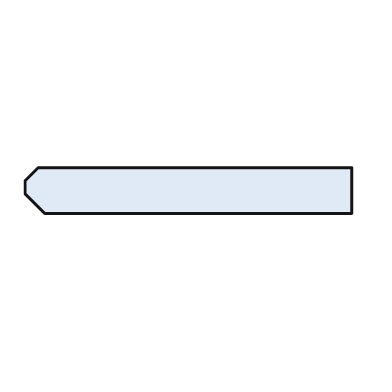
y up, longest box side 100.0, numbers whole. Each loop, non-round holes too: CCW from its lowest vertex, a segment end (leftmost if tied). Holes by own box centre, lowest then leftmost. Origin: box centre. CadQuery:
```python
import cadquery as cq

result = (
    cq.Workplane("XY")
    .moveTo(-44.0, -7.0)
    .lineTo(50.0, -7.0)
    .lineTo(50.0, 7.0)
    .lineTo(-46.0, 7.0)
    .lineTo(-50.0, 3.0)
    .lineTo(-50.0, -1.0)
    .close()
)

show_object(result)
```